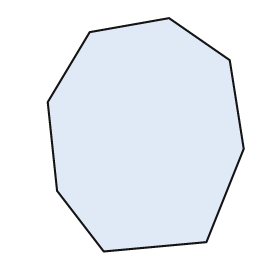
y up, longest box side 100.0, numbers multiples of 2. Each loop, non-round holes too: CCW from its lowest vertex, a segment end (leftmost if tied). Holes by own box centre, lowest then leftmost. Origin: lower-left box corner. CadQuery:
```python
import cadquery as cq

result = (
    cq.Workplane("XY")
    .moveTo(24.0, 0.0)
    .lineTo(68.0, 4.0)
    .lineTo(84.0, 44.0)
    .lineTo(78.0, 82.0)
    .lineTo(52.0, 100.0)
    .lineTo(18.0, 94.0)
    .lineTo(0.0, 64.0)
    .lineTo(4.0, 26.0)
    .close()
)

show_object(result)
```